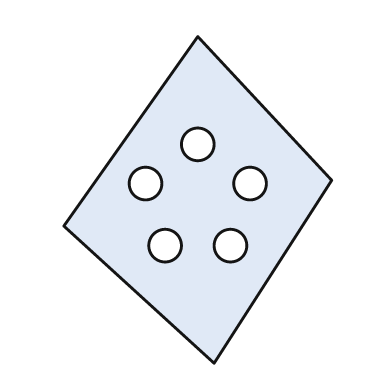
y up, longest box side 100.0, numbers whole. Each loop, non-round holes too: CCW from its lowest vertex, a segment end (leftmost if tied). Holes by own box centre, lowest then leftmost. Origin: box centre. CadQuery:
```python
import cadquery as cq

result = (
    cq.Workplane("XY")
    .moveTo(5.0, -50.0)
    .lineTo(41.0, 6.0)
    .lineTo(0.0, 50.0)
    .lineTo(-41.0, -8.0)
    .close()
    .moveTo(-10.0, -14.0)
    .circle(5.0)
    .moveTo(10.0, -14.0)
    .circle(5.0)
    .moveTo(-16.0, 5.0)
    .circle(5.0)
    .moveTo(16.0, 5.0)
    .circle(5.0)
    .moveTo(0.0, 17.0)
    .circle(5.0)
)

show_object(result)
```